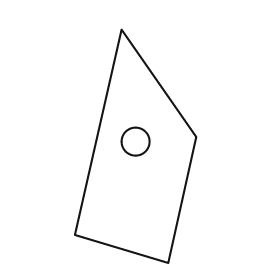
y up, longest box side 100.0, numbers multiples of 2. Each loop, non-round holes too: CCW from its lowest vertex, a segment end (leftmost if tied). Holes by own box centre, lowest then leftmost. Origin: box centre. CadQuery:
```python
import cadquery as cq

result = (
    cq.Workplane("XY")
    .moveTo(14.0, -50.0)
    .lineTo(26.0, 4.0)
    .lineTo(-6.0, 50.0)
    .lineTo(-26.0, -38.0)
    .close()
    .moveTo(0.0, 2.0)
    .circle(6.0)
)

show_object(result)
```